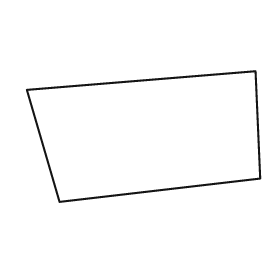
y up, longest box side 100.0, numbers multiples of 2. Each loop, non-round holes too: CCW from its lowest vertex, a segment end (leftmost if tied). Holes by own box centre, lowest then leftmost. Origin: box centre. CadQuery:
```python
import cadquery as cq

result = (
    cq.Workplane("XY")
    .moveTo(-36.0, -28.0)
    .lineTo(50.0, -18.0)
    .lineTo(48.0, 28.0)
    .lineTo(-50.0, 20.0)
    .close()
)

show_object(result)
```